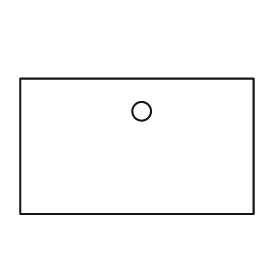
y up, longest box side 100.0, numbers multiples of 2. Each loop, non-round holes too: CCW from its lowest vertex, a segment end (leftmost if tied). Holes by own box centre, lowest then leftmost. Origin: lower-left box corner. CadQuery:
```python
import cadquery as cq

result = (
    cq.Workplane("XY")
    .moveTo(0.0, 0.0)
    .lineTo(100.0, 0.0)
    .lineTo(100.0, 58.0)
    .lineTo(0.0, 58.0)
    .close()
    .moveTo(52.0, 44.0)
    .circle(4.0)
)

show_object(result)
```